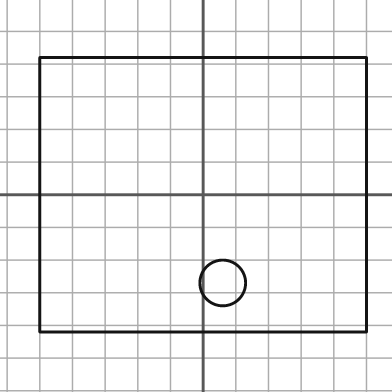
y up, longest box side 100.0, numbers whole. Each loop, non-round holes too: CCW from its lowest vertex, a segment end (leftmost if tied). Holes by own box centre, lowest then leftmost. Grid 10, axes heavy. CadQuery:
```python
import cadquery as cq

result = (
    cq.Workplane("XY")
    .moveTo(-50.0, -42.0)
    .lineTo(50.0, -42.0)
    .lineTo(50.0, 42.0)
    .lineTo(-50.0, 42.0)
    .close()
    .moveTo(6.0, -27.0)
    .circle(7.0)
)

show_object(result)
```